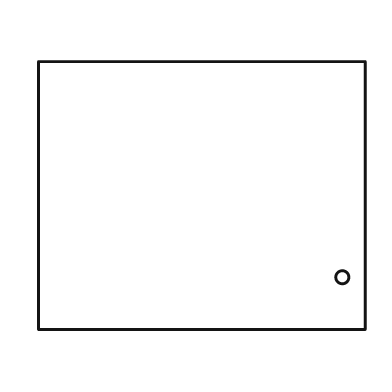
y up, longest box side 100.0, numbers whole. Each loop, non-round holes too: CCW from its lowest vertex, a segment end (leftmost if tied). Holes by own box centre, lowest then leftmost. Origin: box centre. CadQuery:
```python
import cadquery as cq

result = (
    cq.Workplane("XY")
    .moveTo(-50.0, -41.0)
    .lineTo(50.0, -41.0)
    .lineTo(50.0, 41.0)
    .lineTo(-50.0, 41.0)
    .close()
    .moveTo(43.0, -25.0)
    .circle(2.0)
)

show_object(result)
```